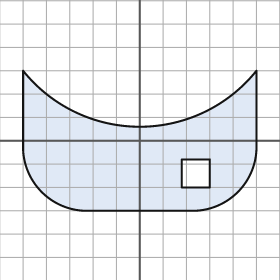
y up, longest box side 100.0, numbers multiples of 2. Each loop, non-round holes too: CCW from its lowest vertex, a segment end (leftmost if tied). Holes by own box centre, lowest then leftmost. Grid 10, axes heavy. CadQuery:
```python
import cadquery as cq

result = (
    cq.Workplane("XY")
    .moveTo(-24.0, -30.0)
    .lineTo(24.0, -30.0)
    .threePointArc((42.0, -22.0), (50.0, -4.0))
    .lineTo(50.0, 30.0)
    .threePointArc((0.0, 6.0), (-50.0, 30.0))
    .lineTo(-50.0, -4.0)
    .threePointArc((-42.0, -22.0), (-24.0, -30.0))
    .close()
    .moveTo(18.0, -20.0)
    .lineTo(30.0, -20.0)
    .lineTo(30.0, -8.0)
    .lineTo(18.0, -8.0)
    .close()
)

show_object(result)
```